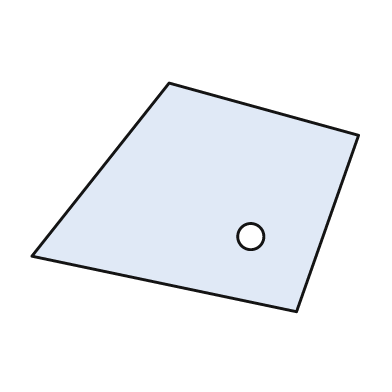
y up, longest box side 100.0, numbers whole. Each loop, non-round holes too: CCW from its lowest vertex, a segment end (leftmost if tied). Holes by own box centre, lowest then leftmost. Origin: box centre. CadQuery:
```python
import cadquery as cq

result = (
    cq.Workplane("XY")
    .moveTo(31.0, -35.0)
    .lineTo(50.0, 19.0)
    .lineTo(-8.0, 35.0)
    .lineTo(-50.0, -18.0)
    .close()
    .moveTo(17.0, -12.0)
    .circle(4.0)
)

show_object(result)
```